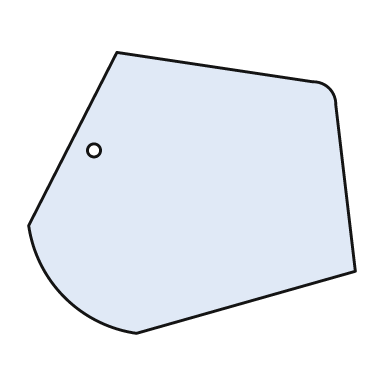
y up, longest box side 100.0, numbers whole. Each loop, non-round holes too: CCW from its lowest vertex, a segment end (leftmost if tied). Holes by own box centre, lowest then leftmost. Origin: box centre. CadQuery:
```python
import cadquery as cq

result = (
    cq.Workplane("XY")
    .moveTo(-17.0, -43.0)
    .lineTo(50.0, -24.0)
    .lineTo(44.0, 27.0)
    .threePointArc((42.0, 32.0), (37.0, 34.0))
    .lineTo(-23.0, 43.0)
    .lineTo(-50.0, -10.0)
    .threePointArc((-39.0, -32.0), (-17.0, -43.0))
    .close()
    .moveTo(-30.0, 13.0)
    .circle(2.0)
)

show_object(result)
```